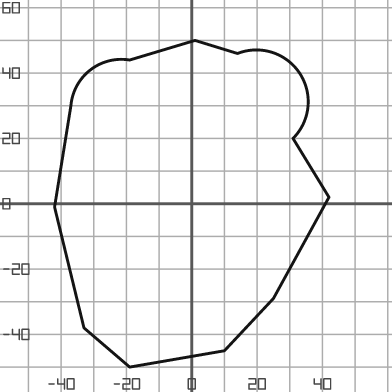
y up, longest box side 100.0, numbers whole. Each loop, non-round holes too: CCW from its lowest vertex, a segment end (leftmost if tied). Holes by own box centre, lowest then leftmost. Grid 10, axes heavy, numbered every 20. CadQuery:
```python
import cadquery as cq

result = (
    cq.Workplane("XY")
    .moveTo(-19.0, -50.0)
    .lineTo(10.0, -45.0)
    .lineTo(25.0, -29.0)
    .lineTo(42.0, 2.0)
    .lineTo(31.0, 20.0)
    .threePointArc((33.0, 40.0), (14.0, 46.0))
    .lineTo(1.0, 50.0)
    .lineTo(-19.0, 44.0)
    .threePointArc((-31.0, 41.0), (-37.0, 30.0))
    .lineTo(-42.0, -1.0)
    .lineTo(-33.0, -38.0)
    .close()
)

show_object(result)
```